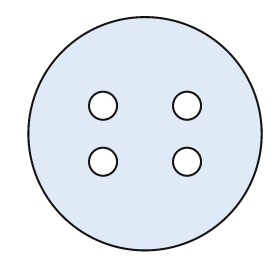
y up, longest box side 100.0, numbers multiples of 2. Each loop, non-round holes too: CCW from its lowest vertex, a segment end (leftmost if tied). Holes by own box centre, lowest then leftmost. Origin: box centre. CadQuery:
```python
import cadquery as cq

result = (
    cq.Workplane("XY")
    .moveTo(0.0, 0.0)
    .circle(50.0)
    .moveTo(-18.0, -12.0)
    .circle(6.0)
    .moveTo(18.0, -12.0)
    .circle(6.0)
    .moveTo(-18.0, 12.0)
    .circle(6.0)
    .moveTo(18.0, 12.0)
    .circle(6.0)
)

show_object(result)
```